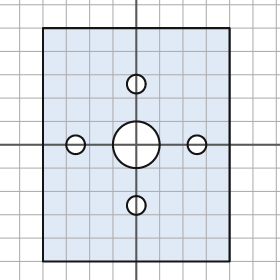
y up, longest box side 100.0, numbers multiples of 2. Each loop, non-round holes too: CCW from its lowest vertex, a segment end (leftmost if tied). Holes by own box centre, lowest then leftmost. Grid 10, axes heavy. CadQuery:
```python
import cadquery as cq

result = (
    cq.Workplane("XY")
    .moveTo(-40.0, -50.0)
    .lineTo(40.0, -50.0)
    .lineTo(40.0, 50.0)
    .lineTo(-40.0, 50.0)
    .close()
    .moveTo(0.0, -26.0)
    .circle(4.0)
    .moveTo(-26.0, 0.0)
    .circle(4.0)
    .moveTo(0.0, 0.0)
    .circle(10.0)
    .moveTo(26.0, 0.0)
    .circle(4.0)
    .moveTo(0.0, 26.0)
    .circle(4.0)
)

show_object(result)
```